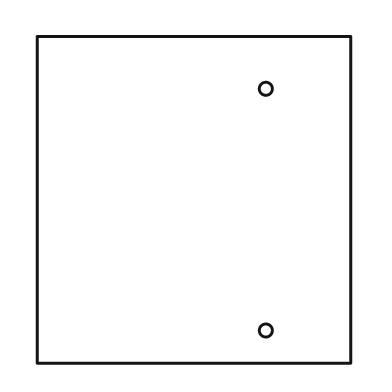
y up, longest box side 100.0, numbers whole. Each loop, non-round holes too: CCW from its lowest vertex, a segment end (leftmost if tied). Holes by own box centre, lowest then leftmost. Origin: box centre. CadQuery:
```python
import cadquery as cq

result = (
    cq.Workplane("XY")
    .moveTo(-48.0, -50.0)
    .lineTo(48.0, -50.0)
    .lineTo(48.0, 50.0)
    .lineTo(-48.0, 50.0)
    .close()
    .moveTo(22.0, -40.0)
    .circle(2.0)
    .moveTo(22.0, 34.0)
    .circle(2.0)
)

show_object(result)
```